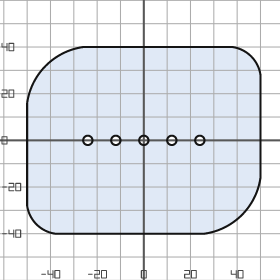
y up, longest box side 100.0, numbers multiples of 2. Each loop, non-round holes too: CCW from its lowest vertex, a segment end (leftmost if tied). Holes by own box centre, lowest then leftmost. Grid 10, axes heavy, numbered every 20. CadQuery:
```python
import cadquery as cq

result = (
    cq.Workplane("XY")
    .moveTo(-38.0, -40.0)
    .lineTo(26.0, -40.0)
    .threePointArc((42.0, -32.0), (50.0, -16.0))
    .lineTo(50.0, 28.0)
    .threePointArc((46.0, 36.0), (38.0, 40.0))
    .lineTo(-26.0, 40.0)
    .threePointArc((-42.0, 32.0), (-50.0, 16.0))
    .lineTo(-50.0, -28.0)
    .threePointArc((-46.0, -36.0), (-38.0, -40.0))
    .close()
    .moveTo(-24.0, 0.0)
    .circle(2.0)
    .moveTo(-12.0, 0.0)
    .circle(2.0)
    .moveTo(0.0, 0.0)
    .circle(2.0)
    .moveTo(12.0, 0.0)
    .circle(2.0)
    .moveTo(24.0, 0.0)
    .circle(2.0)
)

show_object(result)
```